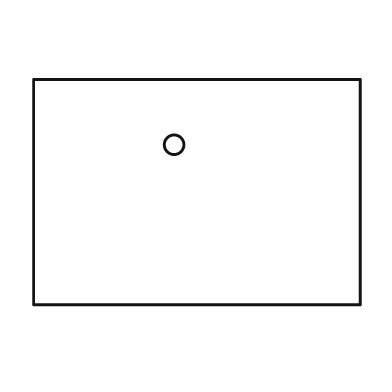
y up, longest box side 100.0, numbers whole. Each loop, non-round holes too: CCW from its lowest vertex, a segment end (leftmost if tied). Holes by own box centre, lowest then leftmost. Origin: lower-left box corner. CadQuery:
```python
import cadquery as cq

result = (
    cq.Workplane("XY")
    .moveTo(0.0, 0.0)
    .lineTo(100.0, 0.0)
    .lineTo(100.0, 69.0)
    .lineTo(0.0, 69.0)
    .close()
    .moveTo(43.0, 49.0)
    .circle(3.0)
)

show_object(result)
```